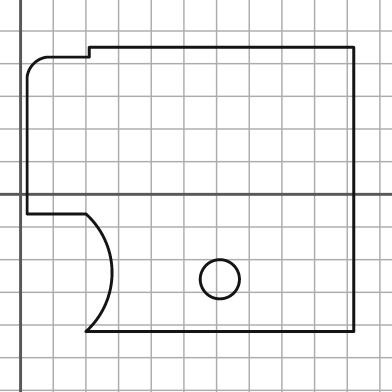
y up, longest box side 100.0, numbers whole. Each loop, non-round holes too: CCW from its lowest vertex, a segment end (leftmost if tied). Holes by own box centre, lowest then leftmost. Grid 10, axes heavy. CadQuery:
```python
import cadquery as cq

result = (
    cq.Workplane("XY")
    .moveTo(20.0, -42.0)
    .lineTo(102.0, -42.0)
    .lineTo(102.0, 45.0)
    .lineTo(21.0, 45.0)
    .lineTo(21.0, 42.0)
    .lineTo(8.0, 42.0)
    .threePointArc((4.0, 40.0), (2.0, 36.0))
    .lineTo(2.0, -6.0)
    .lineTo(20.0, -6.0)
    .threePointArc((28.0, -24.0), (20.0, -42.0))
    .close()
    .moveTo(61.0, -26.0)
    .circle(6.0)
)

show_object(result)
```